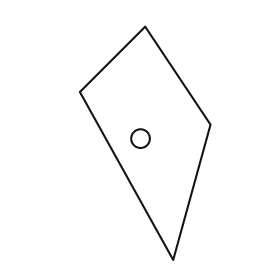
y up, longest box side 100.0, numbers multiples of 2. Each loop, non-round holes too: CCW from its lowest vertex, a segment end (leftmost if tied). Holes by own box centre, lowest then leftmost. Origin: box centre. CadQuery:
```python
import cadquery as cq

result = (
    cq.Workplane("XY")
    .moveTo(12.0, -50.0)
    .lineTo(28.0, 8.0)
    .lineTo(0.0, 50.0)
    .lineTo(-28.0, 22.0)
    .close()
    .moveTo(-2.0, 2.0)
    .circle(4.0)
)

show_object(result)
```